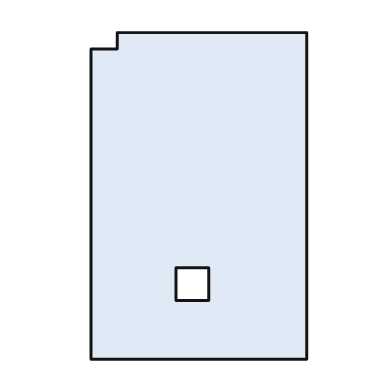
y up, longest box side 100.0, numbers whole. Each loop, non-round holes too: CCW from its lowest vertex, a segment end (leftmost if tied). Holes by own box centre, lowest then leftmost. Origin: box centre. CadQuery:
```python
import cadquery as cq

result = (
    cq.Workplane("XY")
    .moveTo(-33.0, -50.0)
    .lineTo(33.0, -50.0)
    .lineTo(33.0, 50.0)
    .lineTo(-25.0, 50.0)
    .lineTo(-25.0, 45.0)
    .lineTo(-33.0, 45.0)
    .close()
    .moveTo(-7.0, -32.0)
    .lineTo(3.0, -32.0)
    .lineTo(3.0, -22.0)
    .lineTo(-7.0, -22.0)
    .close()
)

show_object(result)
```